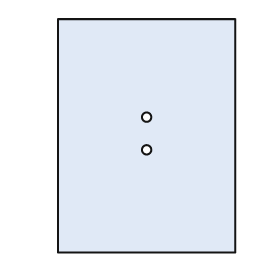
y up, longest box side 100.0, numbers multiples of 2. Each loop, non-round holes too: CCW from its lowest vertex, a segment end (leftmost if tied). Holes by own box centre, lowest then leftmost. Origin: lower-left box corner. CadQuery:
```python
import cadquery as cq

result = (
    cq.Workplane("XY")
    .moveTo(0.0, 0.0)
    .lineTo(76.0, 0.0)
    .lineTo(76.0, 100.0)
    .lineTo(0.0, 100.0)
    .close()
    .moveTo(38.0, 44.0)
    .circle(2.0)
    .moveTo(38.0, 58.0)
    .circle(2.0)
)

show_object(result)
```